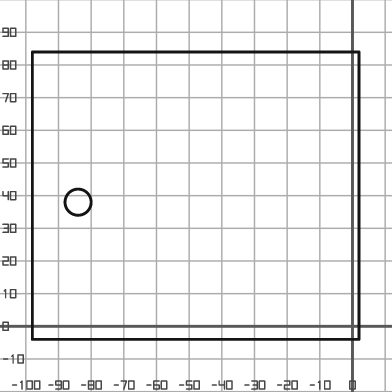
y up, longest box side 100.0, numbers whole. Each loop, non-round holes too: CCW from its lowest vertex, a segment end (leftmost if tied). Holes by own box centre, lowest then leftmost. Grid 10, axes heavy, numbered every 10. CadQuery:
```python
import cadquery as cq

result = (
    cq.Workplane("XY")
    .moveTo(-98.0, -4.0)
    .lineTo(2.0, -4.0)
    .lineTo(2.0, 84.0)
    .lineTo(-98.0, 84.0)
    .close()
    .moveTo(-84.0, 38.0)
    .circle(4.0)
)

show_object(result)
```